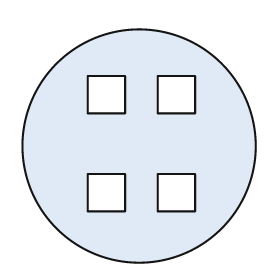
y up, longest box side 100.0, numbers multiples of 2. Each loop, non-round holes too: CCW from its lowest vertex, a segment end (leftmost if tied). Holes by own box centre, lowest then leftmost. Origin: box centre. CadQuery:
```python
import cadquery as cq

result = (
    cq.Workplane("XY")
    .moveTo(0.0, 0.0)
    .circle(50.0)
    .moveTo(-22.0, -28.0)
    .lineTo(-6.0, -28.0)
    .lineTo(-6.0, -12.0)
    .lineTo(-22.0, -12.0)
    .close()
    .moveTo(8.0, -28.0)
    .lineTo(24.0, -28.0)
    .lineTo(24.0, -12.0)
    .lineTo(8.0, -12.0)
    .close()
    .moveTo(-22.0, 14.0)
    .lineTo(-6.0, 14.0)
    .lineTo(-6.0, 30.0)
    .lineTo(-22.0, 30.0)
    .close()
    .moveTo(8.0, 14.0)
    .lineTo(24.0, 14.0)
    .lineTo(24.0, 30.0)
    .lineTo(8.0, 30.0)
    .close()
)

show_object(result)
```